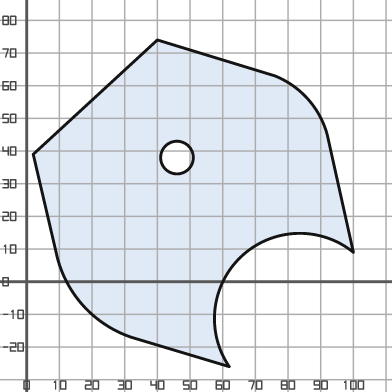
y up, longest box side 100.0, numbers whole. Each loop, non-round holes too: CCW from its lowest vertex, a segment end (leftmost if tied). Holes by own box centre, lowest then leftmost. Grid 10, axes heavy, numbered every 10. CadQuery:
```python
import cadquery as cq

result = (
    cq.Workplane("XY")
    .moveTo(62.0, -26.0)
    .threePointArc((66.0, 8.0), (100.0, 9.0))
    .lineTo(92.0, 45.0)
    .threePointArc((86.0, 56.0), (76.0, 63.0))
    .lineTo(40.0, 74.0)
    .lineTo(2.0, 39.0)
    .lineTo(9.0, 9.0)
    .threePointArc((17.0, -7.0), (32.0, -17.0))
    .close()
    .moveTo(46.0, 38.0)
    .circle(5.0)
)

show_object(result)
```